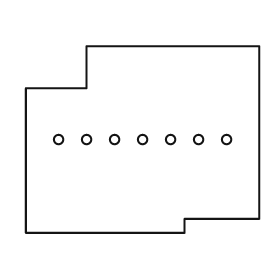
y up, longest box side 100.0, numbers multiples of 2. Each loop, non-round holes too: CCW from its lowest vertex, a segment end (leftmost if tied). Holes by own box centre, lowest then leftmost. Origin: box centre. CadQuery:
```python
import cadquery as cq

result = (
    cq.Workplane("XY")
    .moveTo(-50.0, -40.0)
    .lineTo(18.0, -40.0)
    .lineTo(18.0, -34.0)
    .lineTo(50.0, -34.0)
    .lineTo(50.0, 40.0)
    .lineTo(-24.0, 40.0)
    .lineTo(-24.0, 22.0)
    .lineTo(-50.0, 22.0)
    .close()
    .moveTo(-36.0, 0.0)
    .circle(2.0)
    .moveTo(-24.0, 0.0)
    .circle(2.0)
    .moveTo(-12.0, 0.0)
    .circle(2.0)
    .moveTo(0.0, 0.0)
    .circle(2.0)
    .moveTo(12.0, 0.0)
    .circle(2.0)
    .moveTo(24.0, 0.0)
    .circle(2.0)
    .moveTo(36.0, 0.0)
    .circle(2.0)
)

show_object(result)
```